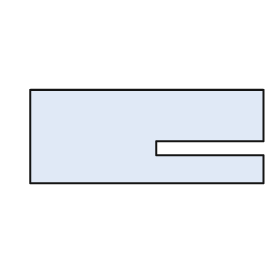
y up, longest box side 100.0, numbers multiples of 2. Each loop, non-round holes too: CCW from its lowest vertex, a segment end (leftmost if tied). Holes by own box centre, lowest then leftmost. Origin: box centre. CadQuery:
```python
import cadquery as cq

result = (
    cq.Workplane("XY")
    .moveTo(-50.0, -20.0)
    .lineTo(50.0, -20.0)
    .lineTo(50.0, -8.0)
    .lineTo(4.0, -8.0)
    .lineTo(4.0, -2.0)
    .lineTo(50.0, -2.0)
    .lineTo(50.0, 20.0)
    .lineTo(-50.0, 20.0)
    .close()
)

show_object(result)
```